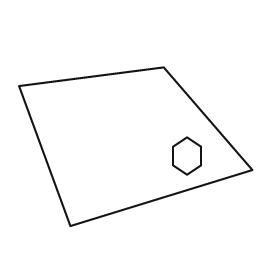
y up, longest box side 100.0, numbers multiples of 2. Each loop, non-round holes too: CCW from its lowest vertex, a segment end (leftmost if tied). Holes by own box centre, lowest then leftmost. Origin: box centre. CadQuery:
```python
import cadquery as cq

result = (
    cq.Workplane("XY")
    .moveTo(-28.0, -34.0)
    .lineTo(50.0, -10.0)
    .lineTo(12.0, 34.0)
    .lineTo(-50.0, 26.0)
    .close()
    .moveTo(22.0, -12.0)
    .lineTo(28.0, -8.0)
    .lineTo(28.0, 0.0)
    .lineTo(22.0, 4.0)
    .lineTo(16.0, 0.0)
    .lineTo(16.0, -8.0)
    .close()
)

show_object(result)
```